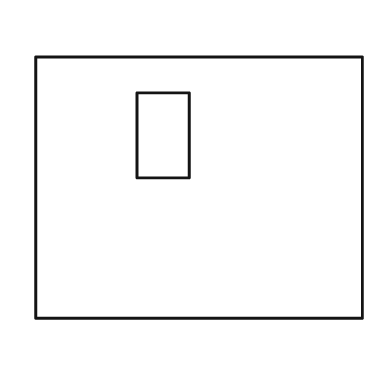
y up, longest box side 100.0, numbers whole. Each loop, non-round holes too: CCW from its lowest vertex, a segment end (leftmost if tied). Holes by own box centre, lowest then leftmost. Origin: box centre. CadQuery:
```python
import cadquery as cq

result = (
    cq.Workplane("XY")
    .moveTo(-50.0, -40.0)
    .lineTo(50.0, -40.0)
    .lineTo(50.0, 40.0)
    .lineTo(-50.0, 40.0)
    .close()
    .moveTo(-19.0, 3.0)
    .lineTo(-3.0, 3.0)
    .lineTo(-3.0, 29.0)
    .lineTo(-19.0, 29.0)
    .close()
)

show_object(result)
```